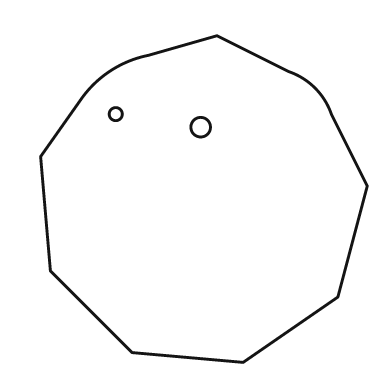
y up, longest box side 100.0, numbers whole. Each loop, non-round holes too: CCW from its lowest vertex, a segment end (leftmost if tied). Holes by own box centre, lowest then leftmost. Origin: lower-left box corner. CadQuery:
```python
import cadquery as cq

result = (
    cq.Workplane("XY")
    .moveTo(62.0, 0.0)
    .lineTo(91.0, 20.0)
    .lineTo(100.0, 54.0)
    .lineTo(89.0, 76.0)
    .threePointArc((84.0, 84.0), (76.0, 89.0))
    .lineTo(54.0, 100.0)
    .lineTo(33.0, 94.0)
    .threePointArc((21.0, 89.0), (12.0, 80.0))
    .lineTo(0.0, 63.0)
    .lineTo(3.0, 28.0)
    .lineTo(28.0, 3.0)
    .close()
    .moveTo(49.0, 72.0)
    .circle(3.0)
    .moveTo(23.0, 76.0)
    .circle(2.0)
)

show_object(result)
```